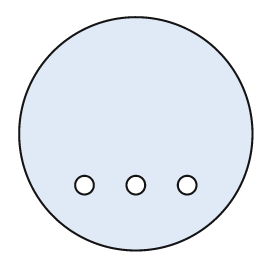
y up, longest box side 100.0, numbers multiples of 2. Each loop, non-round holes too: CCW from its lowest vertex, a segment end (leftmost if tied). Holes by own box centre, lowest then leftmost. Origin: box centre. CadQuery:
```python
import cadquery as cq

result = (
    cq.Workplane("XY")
    .moveTo(0.0, 0.0)
    .circle(50.0)
    .moveTo(-22.0, -22.0)
    .circle(4.0)
    .moveTo(0.0, -22.0)
    .circle(4.0)
    .moveTo(22.0, -22.0)
    .circle(4.0)
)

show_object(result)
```